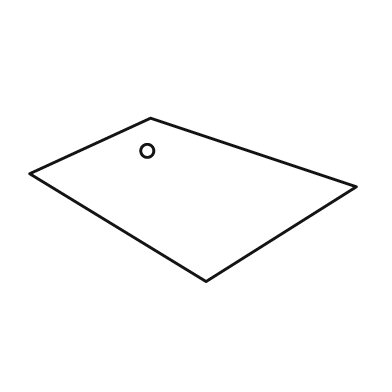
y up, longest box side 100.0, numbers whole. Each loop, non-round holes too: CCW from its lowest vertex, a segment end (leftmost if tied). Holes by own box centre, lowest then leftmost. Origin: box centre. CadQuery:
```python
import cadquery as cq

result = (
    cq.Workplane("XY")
    .moveTo(4.0, -25.0)
    .lineTo(50.0, 4.0)
    .lineTo(-13.0, 25.0)
    .lineTo(-50.0, 8.0)
    .close()
    .moveTo(-14.0, 15.0)
    .circle(2.0)
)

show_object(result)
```